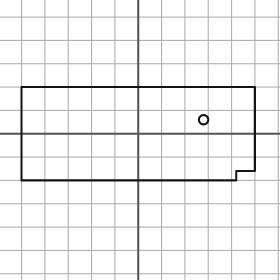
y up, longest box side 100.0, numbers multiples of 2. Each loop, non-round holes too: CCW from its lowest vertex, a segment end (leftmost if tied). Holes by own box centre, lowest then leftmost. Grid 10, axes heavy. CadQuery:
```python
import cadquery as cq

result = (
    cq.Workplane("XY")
    .moveTo(-50.0, -20.0)
    .lineTo(42.0, -20.0)
    .lineTo(42.0, -16.0)
    .lineTo(50.0, -16.0)
    .lineTo(50.0, 20.0)
    .lineTo(-50.0, 20.0)
    .close()
    .moveTo(28.0, 6.0)
    .circle(2.0)
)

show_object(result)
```